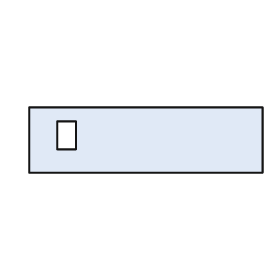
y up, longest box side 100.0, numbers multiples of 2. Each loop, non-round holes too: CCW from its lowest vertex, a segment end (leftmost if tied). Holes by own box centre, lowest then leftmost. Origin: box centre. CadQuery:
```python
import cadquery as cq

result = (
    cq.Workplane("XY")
    .moveTo(-50.0, -14.0)
    .lineTo(50.0, -14.0)
    .lineTo(50.0, 14.0)
    .lineTo(-50.0, 14.0)
    .close()
    .moveTo(-38.0, -4.0)
    .lineTo(-30.0, -4.0)
    .lineTo(-30.0, 8.0)
    .lineTo(-38.0, 8.0)
    .close()
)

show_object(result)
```